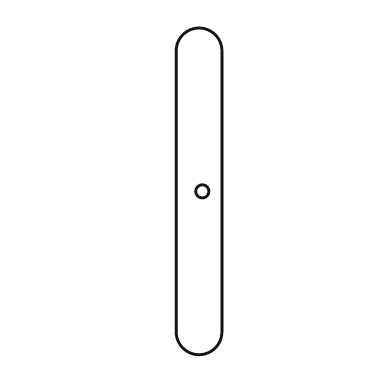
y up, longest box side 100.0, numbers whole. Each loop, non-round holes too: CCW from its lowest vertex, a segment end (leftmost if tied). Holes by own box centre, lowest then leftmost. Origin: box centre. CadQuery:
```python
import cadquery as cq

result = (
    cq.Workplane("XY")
    .moveTo(-7.0, -43.0)
    .threePointArc((0.0, -50.0), (7.0, -43.0))
    .lineTo(7.0, 43.0)
    .threePointArc((0.0, 50.0), (-7.0, 43.0))
    .close()
    .moveTo(1.0, 0.0)
    .circle(2.0)
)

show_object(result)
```